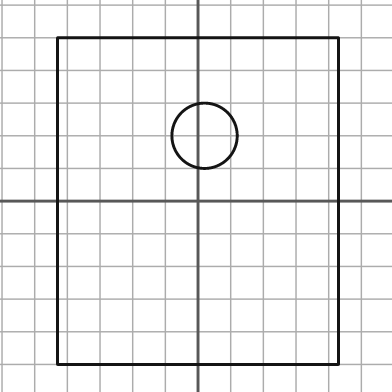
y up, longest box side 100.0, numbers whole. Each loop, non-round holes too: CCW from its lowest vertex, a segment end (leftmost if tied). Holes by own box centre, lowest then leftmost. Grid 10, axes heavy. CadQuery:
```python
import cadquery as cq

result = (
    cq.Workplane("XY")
    .moveTo(-43.0, -50.0)
    .lineTo(43.0, -50.0)
    .lineTo(43.0, 50.0)
    .lineTo(-43.0, 50.0)
    .close()
    .moveTo(2.0, 20.0)
    .circle(10.0)
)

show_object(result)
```